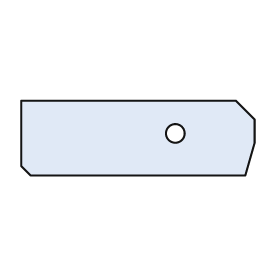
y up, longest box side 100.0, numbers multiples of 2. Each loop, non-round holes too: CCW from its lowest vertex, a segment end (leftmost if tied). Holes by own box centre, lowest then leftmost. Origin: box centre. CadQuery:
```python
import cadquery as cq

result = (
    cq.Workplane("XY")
    .moveTo(-46.0, -16.0)
    .lineTo(46.0, -16.0)
    .lineTo(50.0, -2.0)
    .lineTo(50.0, 8.0)
    .lineTo(42.0, 16.0)
    .lineTo(-50.0, 16.0)
    .lineTo(-50.0, -12.0)
    .close()
    .moveTo(16.0, 2.0)
    .circle(4.0)
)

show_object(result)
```